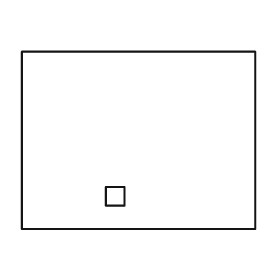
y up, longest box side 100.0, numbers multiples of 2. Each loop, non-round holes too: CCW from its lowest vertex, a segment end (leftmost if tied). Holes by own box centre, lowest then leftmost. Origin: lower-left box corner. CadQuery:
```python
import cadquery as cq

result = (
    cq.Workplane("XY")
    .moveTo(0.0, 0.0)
    .lineTo(100.0, 0.0)
    .lineTo(100.0, 76.0)
    .lineTo(0.0, 76.0)
    .close()
    .moveTo(36.0, 10.0)
    .lineTo(44.0, 10.0)
    .lineTo(44.0, 18.0)
    .lineTo(36.0, 18.0)
    .close()
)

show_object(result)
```